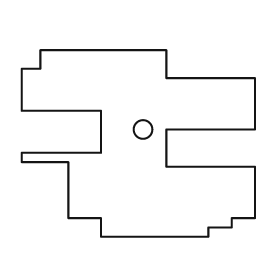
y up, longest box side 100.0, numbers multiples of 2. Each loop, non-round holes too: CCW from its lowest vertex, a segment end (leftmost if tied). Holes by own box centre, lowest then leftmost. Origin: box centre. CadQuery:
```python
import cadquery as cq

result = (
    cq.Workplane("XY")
    .moveTo(-16.0, -40.0)
    .lineTo(30.0, -40.0)
    .lineTo(30.0, -36.0)
    .lineTo(40.0, -36.0)
    .lineTo(40.0, -32.0)
    .lineTo(50.0, -32.0)
    .lineTo(50.0, -10.0)
    .lineTo(12.0, -10.0)
    .lineTo(12.0, 6.0)
    .lineTo(50.0, 6.0)
    .lineTo(50.0, 28.0)
    .lineTo(12.0, 28.0)
    .lineTo(12.0, 40.0)
    .lineTo(-42.0, 40.0)
    .lineTo(-42.0, 32.0)
    .lineTo(-50.0, 32.0)
    .lineTo(-50.0, 14.0)
    .lineTo(-16.0, 14.0)
    .lineTo(-16.0, -4.0)
    .lineTo(-50.0, -4.0)
    .lineTo(-50.0, -8.0)
    .lineTo(-30.0, -8.0)
    .lineTo(-30.0, -32.0)
    .lineTo(-16.0, -32.0)
    .close()
    .moveTo(2.0, 6.0)
    .circle(4.0)
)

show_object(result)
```